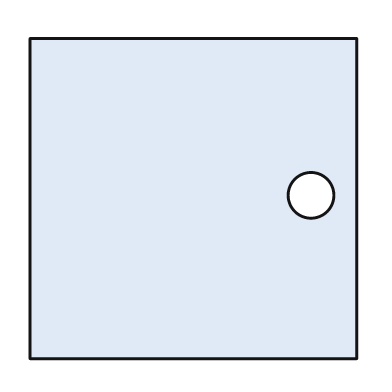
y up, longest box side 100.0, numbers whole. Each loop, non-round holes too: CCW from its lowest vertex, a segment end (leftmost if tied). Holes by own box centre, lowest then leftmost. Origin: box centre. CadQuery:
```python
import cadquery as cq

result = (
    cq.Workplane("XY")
    .moveTo(-50.0, -49.0)
    .lineTo(50.0, -49.0)
    .lineTo(50.0, 49.0)
    .lineTo(-50.0, 49.0)
    .close()
    .moveTo(36.0, 1.0)
    .circle(7.0)
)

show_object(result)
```